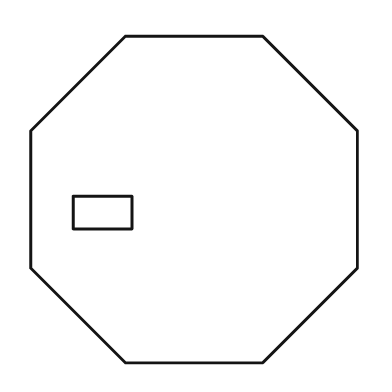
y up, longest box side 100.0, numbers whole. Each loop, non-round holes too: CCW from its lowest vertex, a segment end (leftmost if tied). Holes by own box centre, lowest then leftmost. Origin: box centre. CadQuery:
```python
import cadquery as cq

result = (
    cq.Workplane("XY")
    .moveTo(-21.0, -50.0)
    .lineTo(21.0, -50.0)
    .lineTo(50.0, -21.0)
    .lineTo(50.0, 21.0)
    .lineTo(21.0, 50.0)
    .lineTo(-21.0, 50.0)
    .lineTo(-50.0, 21.0)
    .lineTo(-50.0, -21.0)
    .close()
    .moveTo(-37.0, -9.0)
    .lineTo(-19.0, -9.0)
    .lineTo(-19.0, 1.0)
    .lineTo(-37.0, 1.0)
    .close()
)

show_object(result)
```